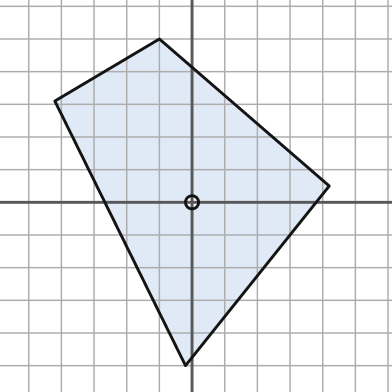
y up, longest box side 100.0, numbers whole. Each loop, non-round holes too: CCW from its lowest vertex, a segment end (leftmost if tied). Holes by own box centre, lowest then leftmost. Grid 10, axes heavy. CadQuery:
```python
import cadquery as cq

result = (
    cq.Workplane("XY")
    .moveTo(-2.0, -50.0)
    .lineTo(42.0, 5.0)
    .lineTo(-10.0, 50.0)
    .lineTo(-42.0, 31.0)
    .close()
    .moveTo(0.0, 0.0)
    .circle(2.0)
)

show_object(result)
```